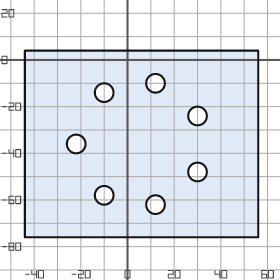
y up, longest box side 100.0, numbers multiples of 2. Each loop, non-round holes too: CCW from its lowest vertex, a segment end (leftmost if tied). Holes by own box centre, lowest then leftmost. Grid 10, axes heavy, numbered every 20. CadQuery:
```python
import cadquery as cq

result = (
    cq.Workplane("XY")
    .moveTo(-44.0, -76.0)
    .lineTo(56.0, -76.0)
    .lineTo(56.0, 4.0)
    .lineTo(-44.0, 4.0)
    .close()
    .moveTo(12.0, -62.0)
    .circle(4.0)
    .moveTo(-10.0, -58.0)
    .circle(4.0)
    .moveTo(30.0, -48.0)
    .circle(4.0)
    .moveTo(-22.0, -36.0)
    .circle(4.0)
    .moveTo(30.0, -24.0)
    .circle(4.0)
    .moveTo(-10.0, -14.0)
    .circle(4.0)
    .moveTo(12.0, -10.0)
    .circle(4.0)
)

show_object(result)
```